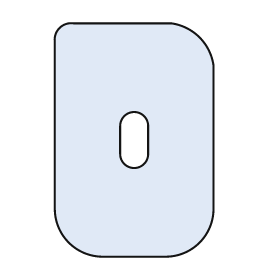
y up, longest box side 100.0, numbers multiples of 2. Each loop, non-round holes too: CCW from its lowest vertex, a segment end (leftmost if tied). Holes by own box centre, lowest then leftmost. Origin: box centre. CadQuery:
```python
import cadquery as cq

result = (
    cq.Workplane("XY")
    .moveTo(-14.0, -50.0)
    .lineTo(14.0, -50.0)
    .threePointArc((28.0, -44.0), (34.0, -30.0))
    .lineTo(34.0, 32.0)
    .threePointArc((28.0, 44.0), (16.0, 50.0))
    .lineTo(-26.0, 50.0)
    .threePointArc((-32.0, 48.0), (-34.0, 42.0))
    .lineTo(-34.0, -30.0)
    .threePointArc((-28.0, -44.0), (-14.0, -50.0))
    .close()
    .moveTo(-6.0, -6.0)
    .threePointArc((0.0, -12.0), (6.0, -6.0))
    .lineTo(6.0, 6.0)
    .threePointArc((0.0, 12.0), (-6.0, 6.0))
    .close()
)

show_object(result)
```